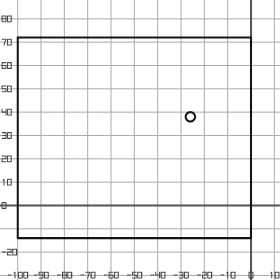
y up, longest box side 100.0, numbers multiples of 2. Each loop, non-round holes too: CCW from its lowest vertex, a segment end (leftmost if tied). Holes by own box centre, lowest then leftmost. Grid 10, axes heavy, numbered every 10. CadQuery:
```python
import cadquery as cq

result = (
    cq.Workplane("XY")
    .moveTo(-100.0, -14.0)
    .lineTo(0.0, -14.0)
    .lineTo(0.0, 72.0)
    .lineTo(-100.0, 72.0)
    .close()
    .moveTo(-26.0, 38.0)
    .circle(2.0)
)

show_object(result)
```